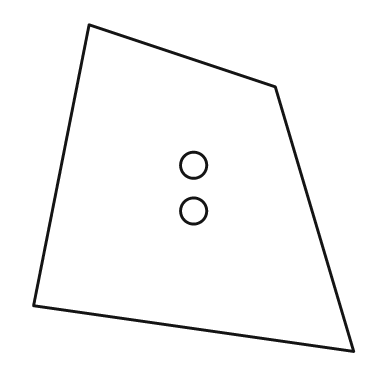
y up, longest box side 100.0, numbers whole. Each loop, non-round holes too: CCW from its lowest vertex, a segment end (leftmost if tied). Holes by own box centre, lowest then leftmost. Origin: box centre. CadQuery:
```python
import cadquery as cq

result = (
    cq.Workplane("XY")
    .moveTo(49.0, -50.0)
    .lineTo(25.0, 31.0)
    .lineTo(-32.0, 50.0)
    .lineTo(-49.0, -36.0)
    .close()
    .moveTo(0.0, -7.0)
    .circle(4.0)
    .moveTo(0.0, 7.0)
    .circle(4.0)
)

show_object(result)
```